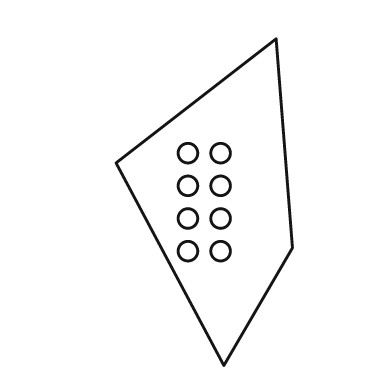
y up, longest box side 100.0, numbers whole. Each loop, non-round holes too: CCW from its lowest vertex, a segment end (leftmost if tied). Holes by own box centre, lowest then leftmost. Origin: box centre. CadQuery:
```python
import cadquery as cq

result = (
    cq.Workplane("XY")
    .moveTo(6.0, -50.0)
    .lineTo(27.0, -14.0)
    .lineTo(22.0, 50.0)
    .lineTo(-27.0, 12.0)
    .close()
    .moveTo(-5.0, -15.0)
    .circle(3.0)
    .moveTo(5.0, -15.0)
    .circle(3.0)
    .moveTo(-5.0, -5.0)
    .circle(3.0)
    .moveTo(5.0, -5.0)
    .circle(3.0)
    .moveTo(-5.0, 5.0)
    .circle(3.0)
    .moveTo(5.0, 5.0)
    .circle(3.0)
    .moveTo(-5.0, 15.0)
    .circle(3.0)
    .moveTo(5.0, 15.0)
    .circle(3.0)
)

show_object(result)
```